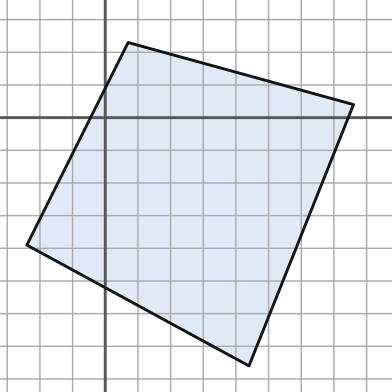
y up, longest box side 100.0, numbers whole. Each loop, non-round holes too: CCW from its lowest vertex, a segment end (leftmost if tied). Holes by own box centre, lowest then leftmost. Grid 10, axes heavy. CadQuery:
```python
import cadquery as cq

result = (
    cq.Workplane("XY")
    .moveTo(44.0, -76.0)
    .lineTo(76.0, 4.0)
    .lineTo(7.0, 23.0)
    .lineTo(-24.0, -39.0)
    .close()
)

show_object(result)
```